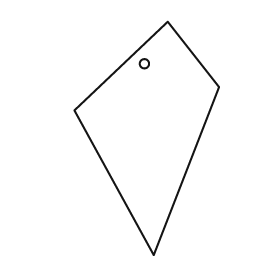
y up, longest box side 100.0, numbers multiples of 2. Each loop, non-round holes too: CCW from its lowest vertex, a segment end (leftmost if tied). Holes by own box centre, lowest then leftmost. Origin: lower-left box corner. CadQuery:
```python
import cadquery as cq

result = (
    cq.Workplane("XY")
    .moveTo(34.0, 0.0)
    .lineTo(62.0, 72.0)
    .lineTo(40.0, 100.0)
    .lineTo(0.0, 62.0)
    .close()
    .moveTo(30.0, 82.0)
    .circle(2.0)
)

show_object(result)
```